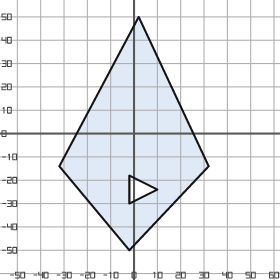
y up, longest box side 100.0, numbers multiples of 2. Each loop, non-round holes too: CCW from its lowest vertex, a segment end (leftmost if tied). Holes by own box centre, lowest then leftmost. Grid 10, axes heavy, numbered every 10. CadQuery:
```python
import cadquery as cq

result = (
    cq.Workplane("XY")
    .moveTo(-2.0, -50.0)
    .lineTo(32.0, -14.0)
    .lineTo(2.0, 50.0)
    .lineTo(-32.0, -14.0)
    .close()
    .moveTo(-2.0, -30.0)
    .lineTo(10.0, -24.0)
    .lineTo(-2.0, -18.0)
    .close()
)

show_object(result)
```